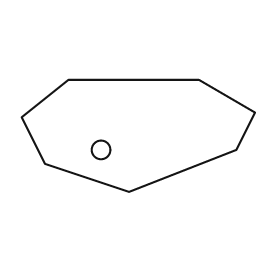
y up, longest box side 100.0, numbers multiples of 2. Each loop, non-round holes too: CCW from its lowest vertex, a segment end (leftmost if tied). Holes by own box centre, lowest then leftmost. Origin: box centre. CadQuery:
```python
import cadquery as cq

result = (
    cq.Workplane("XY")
    .moveTo(-4.0, -24.0)
    .lineTo(42.0, -6.0)
    .lineTo(50.0, 10.0)
    .lineTo(26.0, 24.0)
    .lineTo(-30.0, 24.0)
    .lineTo(-50.0, 8.0)
    .lineTo(-40.0, -12.0)
    .close()
    .moveTo(-16.0, -6.0)
    .circle(4.0)
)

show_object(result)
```